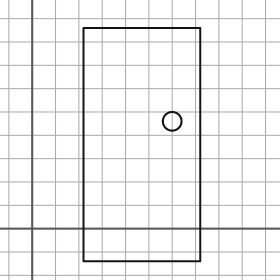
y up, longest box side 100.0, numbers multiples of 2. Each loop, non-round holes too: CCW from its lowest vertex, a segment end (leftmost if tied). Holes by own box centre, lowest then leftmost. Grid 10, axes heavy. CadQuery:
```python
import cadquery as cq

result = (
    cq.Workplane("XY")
    .moveTo(22.0, -14.0)
    .lineTo(72.0, -14.0)
    .lineTo(72.0, 86.0)
    .lineTo(22.0, 86.0)
    .close()
    .moveTo(60.0, 46.0)
    .circle(4.0)
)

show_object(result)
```